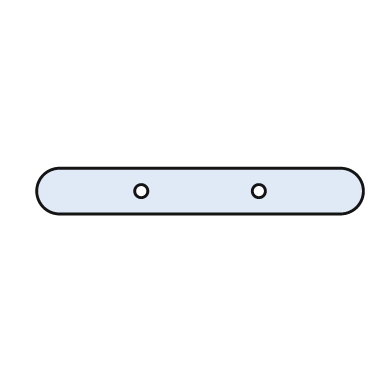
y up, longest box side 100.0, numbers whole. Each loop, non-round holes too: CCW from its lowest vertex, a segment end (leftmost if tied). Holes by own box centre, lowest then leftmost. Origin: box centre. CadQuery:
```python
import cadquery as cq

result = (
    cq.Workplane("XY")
    .moveTo(-43.0, -7.0)
    .lineTo(43.0, -7.0)
    .threePointArc((50.0, 0.0), (43.0, 7.0))
    .lineTo(-43.0, 7.0)
    .threePointArc((-50.0, 0.0), (-43.0, -7.0))
    .close()
    .moveTo(-18.0, 0.0)
    .circle(2.0)
    .moveTo(18.0, 0.0)
    .circle(2.0)
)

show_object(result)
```